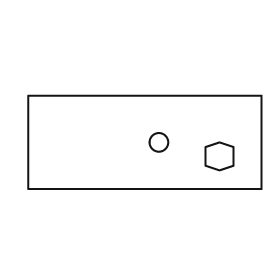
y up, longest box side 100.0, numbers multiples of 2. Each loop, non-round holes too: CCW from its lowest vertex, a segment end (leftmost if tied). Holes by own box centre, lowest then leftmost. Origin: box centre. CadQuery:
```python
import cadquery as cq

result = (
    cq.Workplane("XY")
    .moveTo(-50.0, -20.0)
    .lineTo(50.0, -20.0)
    .lineTo(50.0, 20.0)
    .lineTo(-50.0, 20.0)
    .close()
    .moveTo(32.0, -12.0)
    .lineTo(38.0, -10.0)
    .lineTo(38.0, -2.0)
    .lineTo(32.0, 0.0)
    .lineTo(26.0, -2.0)
    .lineTo(26.0, -10.0)
    .close()
    .moveTo(6.0, 0.0)
    .circle(4.0)
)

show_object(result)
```